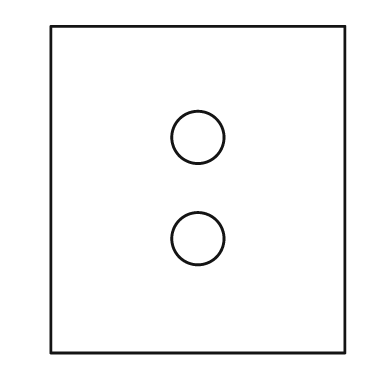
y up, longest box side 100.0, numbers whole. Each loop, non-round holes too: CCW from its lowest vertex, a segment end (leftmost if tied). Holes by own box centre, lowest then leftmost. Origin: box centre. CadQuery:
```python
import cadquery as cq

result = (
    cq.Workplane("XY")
    .moveTo(-45.0, -50.0)
    .lineTo(45.0, -50.0)
    .lineTo(45.0, 50.0)
    .lineTo(-45.0, 50.0)
    .close()
    .moveTo(0.0, -15.0)
    .circle(8.0)
    .moveTo(0.0, 16.0)
    .circle(8.0)
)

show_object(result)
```